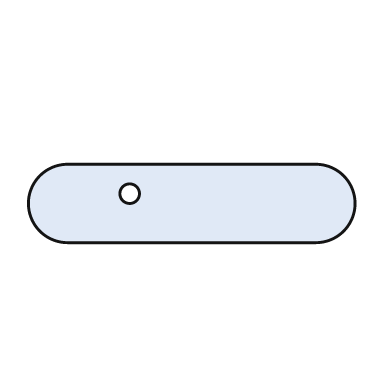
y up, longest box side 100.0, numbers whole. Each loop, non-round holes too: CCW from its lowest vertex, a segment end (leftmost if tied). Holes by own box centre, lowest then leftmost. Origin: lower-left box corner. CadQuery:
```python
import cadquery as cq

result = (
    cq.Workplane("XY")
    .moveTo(12.0, 0.0)
    .lineTo(88.0, 0.0)
    .threePointArc((100.0, 12.0), (88.0, 24.0))
    .lineTo(12.0, 24.0)
    .threePointArc((0.0, 12.0), (12.0, 0.0))
    .close()
    .moveTo(31.0, 15.0)
    .circle(3.0)
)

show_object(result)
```